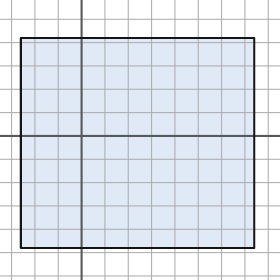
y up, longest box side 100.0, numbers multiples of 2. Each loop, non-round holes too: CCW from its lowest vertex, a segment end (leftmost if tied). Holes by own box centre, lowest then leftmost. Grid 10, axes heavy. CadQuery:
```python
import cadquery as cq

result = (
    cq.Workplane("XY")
    .moveTo(-26.0, -48.0)
    .lineTo(74.0, -48.0)
    .lineTo(74.0, 42.0)
    .lineTo(-26.0, 42.0)
    .close()
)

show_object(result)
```